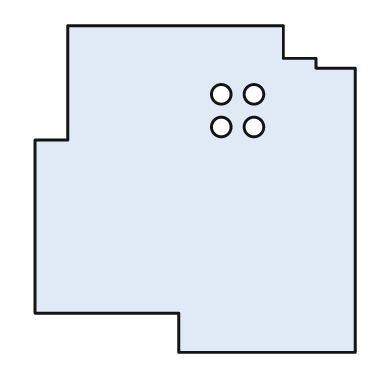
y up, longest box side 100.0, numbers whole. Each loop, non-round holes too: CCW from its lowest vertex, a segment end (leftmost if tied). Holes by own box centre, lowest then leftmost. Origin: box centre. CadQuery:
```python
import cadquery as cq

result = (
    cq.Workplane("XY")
    .moveTo(-5.0, -50.0)
    .lineTo(49.0, -50.0)
    .lineTo(49.0, 37.0)
    .lineTo(37.0, 37.0)
    .lineTo(37.0, 40.0)
    .lineTo(27.0, 40.0)
    .lineTo(27.0, 50.0)
    .lineTo(-39.0, 50.0)
    .lineTo(-39.0, 15.0)
    .lineTo(-49.0, 15.0)
    .lineTo(-49.0, -38.0)
    .lineTo(-5.0, -38.0)
    .close()
    .moveTo(8.0, 19.0)
    .circle(3.0)
    .moveTo(18.0, 19.0)
    .circle(3.0)
    .moveTo(8.0, 29.0)
    .circle(3.0)
    .moveTo(18.0, 29.0)
    .circle(3.0)
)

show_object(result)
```